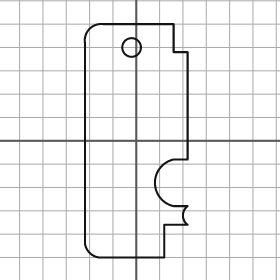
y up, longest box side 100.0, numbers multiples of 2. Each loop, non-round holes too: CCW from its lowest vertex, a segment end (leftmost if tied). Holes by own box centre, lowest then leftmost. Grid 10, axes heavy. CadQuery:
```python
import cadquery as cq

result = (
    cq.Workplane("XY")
    .moveTo(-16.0, -50.0)
    .lineTo(12.0, -50.0)
    .lineTo(12.0, -36.0)
    .lineTo(22.0, -36.0)
    .threePointArc((20.0, -32.0), (22.0, -28.0))
    .lineTo(16.0, -28.0)
    .threePointArc((8.0, -18.0), (16.0, -8.0))
    .lineTo(22.0, -8.0)
    .lineTo(22.0, 38.0)
    .lineTo(16.0, 38.0)
    .lineTo(16.0, 50.0)
    .lineTo(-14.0, 50.0)
    .threePointArc((-20.0, 48.0), (-22.0, 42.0))
    .lineTo(-22.0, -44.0)
    .threePointArc((-20.0, -48.0), (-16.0, -50.0))
    .close()
    .moveTo(-2.0, 40.0)
    .circle(4.0)
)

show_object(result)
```